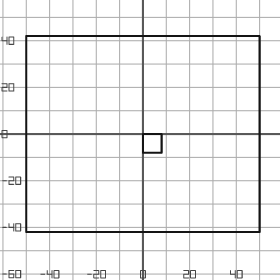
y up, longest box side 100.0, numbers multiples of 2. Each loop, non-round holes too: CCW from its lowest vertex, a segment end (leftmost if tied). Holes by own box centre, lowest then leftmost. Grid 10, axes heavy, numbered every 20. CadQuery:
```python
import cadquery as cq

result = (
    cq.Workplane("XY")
    .moveTo(-50.0, -42.0)
    .lineTo(50.0, -42.0)
    .lineTo(50.0, 42.0)
    .lineTo(-50.0, 42.0)
    .close()
    .moveTo(0.0, -8.0)
    .lineTo(8.0, -8.0)
    .lineTo(8.0, 0.0)
    .lineTo(0.0, 0.0)
    .close()
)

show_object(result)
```